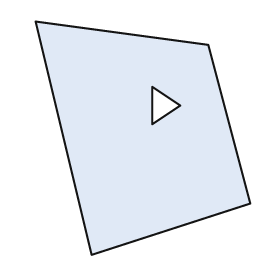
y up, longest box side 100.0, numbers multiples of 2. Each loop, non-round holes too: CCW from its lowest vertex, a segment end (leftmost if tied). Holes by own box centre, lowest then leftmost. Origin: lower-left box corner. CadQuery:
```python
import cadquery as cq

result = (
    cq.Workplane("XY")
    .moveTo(24.0, 0.0)
    .lineTo(92.0, 22.0)
    .lineTo(74.0, 90.0)
    .lineTo(0.0, 100.0)
    .close()
    .moveTo(50.0, 56.0)
    .lineTo(62.0, 64.0)
    .lineTo(50.0, 72.0)
    .close()
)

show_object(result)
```